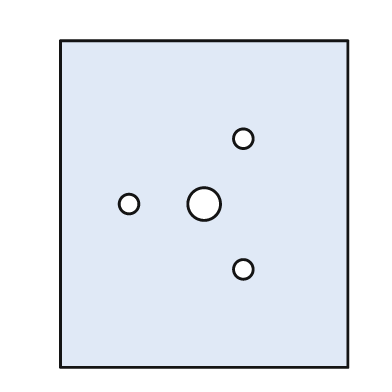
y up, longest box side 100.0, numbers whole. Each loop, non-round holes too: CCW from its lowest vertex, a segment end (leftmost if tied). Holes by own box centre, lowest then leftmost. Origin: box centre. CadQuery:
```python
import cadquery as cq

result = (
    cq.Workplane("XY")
    .moveTo(-44.0, -50.0)
    .lineTo(44.0, -50.0)
    .lineTo(44.0, 50.0)
    .lineTo(-44.0, 50.0)
    .close()
    .moveTo(12.0, -20.0)
    .circle(3.0)
    .moveTo(-23.0, 0.0)
    .circle(3.0)
    .moveTo(0.0, 0.0)
    .circle(5.0)
    .moveTo(12.0, 20.0)
    .circle(3.0)
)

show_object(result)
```